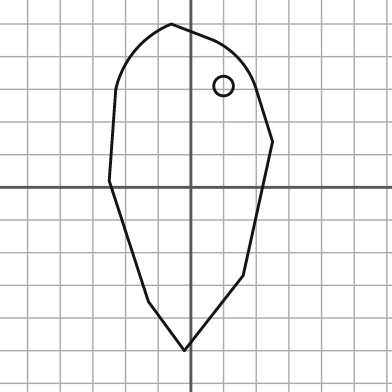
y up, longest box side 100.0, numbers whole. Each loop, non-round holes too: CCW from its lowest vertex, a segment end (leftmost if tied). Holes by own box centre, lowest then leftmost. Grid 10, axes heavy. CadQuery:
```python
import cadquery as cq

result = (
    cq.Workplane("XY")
    .moveTo(-2.0, -50.0)
    .lineTo(16.0, -27.0)
    .lineTo(25.0, 14.0)
    .lineTo(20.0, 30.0)
    .threePointArc((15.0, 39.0), (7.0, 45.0))
    .lineTo(-6.0, 50.0)
    .threePointArc((-17.0, 42.0), (-23.0, 30.0))
    .lineTo(-25.0, 2.0)
    .lineTo(-13.0, -35.0)
    .close()
    .moveTo(10.0, 31.0)
    .circle(3.0)
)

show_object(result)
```